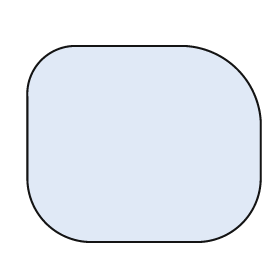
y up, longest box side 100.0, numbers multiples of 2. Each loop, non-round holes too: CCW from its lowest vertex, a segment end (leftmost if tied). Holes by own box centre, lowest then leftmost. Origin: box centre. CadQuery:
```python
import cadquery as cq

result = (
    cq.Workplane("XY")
    .moveTo(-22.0, -42.0)
    .lineTo(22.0, -42.0)
    .threePointArc((42.0, -34.0), (50.0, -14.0))
    .lineTo(50.0, 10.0)
    .threePointArc((40.0, 32.0), (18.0, 42.0))
    .lineTo(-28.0, 42.0)
    .threePointArc((-44.0, 36.0), (-50.0, 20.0))
    .lineTo(-50.0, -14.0)
    .threePointArc((-42.0, -34.0), (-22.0, -42.0))
    .close()
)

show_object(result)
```